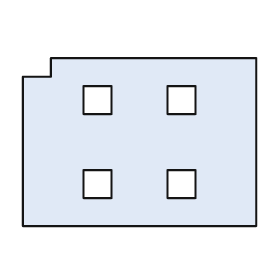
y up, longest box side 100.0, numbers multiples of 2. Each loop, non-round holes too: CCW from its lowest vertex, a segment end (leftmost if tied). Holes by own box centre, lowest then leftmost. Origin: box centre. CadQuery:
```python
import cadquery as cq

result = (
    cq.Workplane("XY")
    .moveTo(-50.0, -36.0)
    .lineTo(50.0, -36.0)
    .lineTo(50.0, 36.0)
    .lineTo(-38.0, 36.0)
    .lineTo(-38.0, 28.0)
    .lineTo(-50.0, 28.0)
    .close()
    .moveTo(-24.0, -24.0)
    .lineTo(-12.0, -24.0)
    .lineTo(-12.0, -12.0)
    .lineTo(-24.0, -12.0)
    .close()
    .moveTo(12.0, -24.0)
    .lineTo(24.0, -24.0)
    .lineTo(24.0, -12.0)
    .lineTo(12.0, -12.0)
    .close()
    .moveTo(-24.0, 12.0)
    .lineTo(-12.0, 12.0)
    .lineTo(-12.0, 24.0)
    .lineTo(-24.0, 24.0)
    .close()
    .moveTo(12.0, 12.0)
    .lineTo(24.0, 12.0)
    .lineTo(24.0, 24.0)
    .lineTo(12.0, 24.0)
    .close()
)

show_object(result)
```